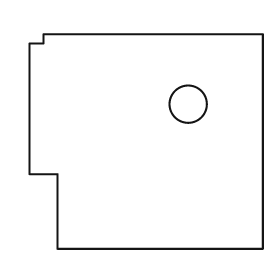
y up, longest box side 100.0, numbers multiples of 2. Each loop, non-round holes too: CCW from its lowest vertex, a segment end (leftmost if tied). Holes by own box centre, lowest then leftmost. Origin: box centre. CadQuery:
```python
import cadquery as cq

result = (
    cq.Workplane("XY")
    .moveTo(-38.0, -46.0)
    .lineTo(50.0, -46.0)
    .lineTo(50.0, 46.0)
    .lineTo(-44.0, 46.0)
    .lineTo(-44.0, 42.0)
    .lineTo(-50.0, 42.0)
    .lineTo(-50.0, -14.0)
    .lineTo(-38.0, -14.0)
    .close()
    .moveTo(18.0, 16.0)
    .circle(8.0)
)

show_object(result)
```